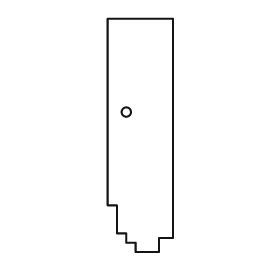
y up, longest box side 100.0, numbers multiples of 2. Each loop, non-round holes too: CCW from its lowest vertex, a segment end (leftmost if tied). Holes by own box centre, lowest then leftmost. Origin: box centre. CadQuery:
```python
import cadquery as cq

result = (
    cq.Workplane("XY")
    .moveTo(-2.0, -50.0)
    .lineTo(8.0, -50.0)
    .lineTo(8.0, -44.0)
    .lineTo(14.0, -44.0)
    .lineTo(14.0, 50.0)
    .lineTo(-14.0, 50.0)
    .lineTo(-14.0, -30.0)
    .lineTo(-10.0, -30.0)
    .lineTo(-10.0, -42.0)
    .lineTo(-6.0, -42.0)
    .lineTo(-6.0, -46.0)
    .lineTo(-2.0, -46.0)
    .close()
    .moveTo(-6.0, 10.0)
    .circle(2.0)
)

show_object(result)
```